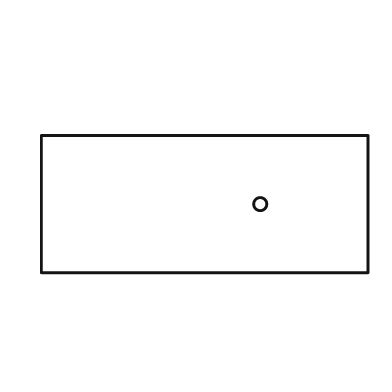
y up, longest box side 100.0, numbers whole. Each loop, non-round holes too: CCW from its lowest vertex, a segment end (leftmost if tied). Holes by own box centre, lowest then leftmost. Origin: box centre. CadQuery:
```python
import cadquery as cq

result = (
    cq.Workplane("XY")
    .moveTo(-50.0, -21.0)
    .lineTo(50.0, -21.0)
    .lineTo(50.0, 21.0)
    .lineTo(-50.0, 21.0)
    .close()
    .moveTo(17.0, 0.0)
    .circle(2.0)
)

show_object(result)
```